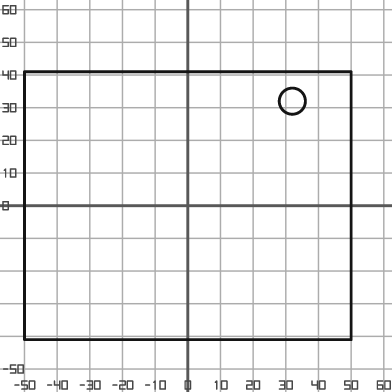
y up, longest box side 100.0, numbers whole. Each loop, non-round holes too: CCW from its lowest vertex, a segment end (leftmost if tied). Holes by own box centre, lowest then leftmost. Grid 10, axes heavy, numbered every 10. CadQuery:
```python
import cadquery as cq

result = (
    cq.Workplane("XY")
    .moveTo(-50.0, -41.0)
    .lineTo(50.0, -41.0)
    .lineTo(50.0, 41.0)
    .lineTo(-50.0, 41.0)
    .close()
    .moveTo(32.0, 32.0)
    .circle(4.0)
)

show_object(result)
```